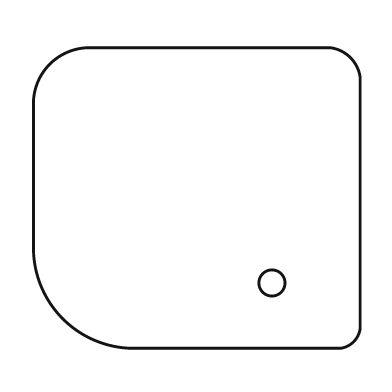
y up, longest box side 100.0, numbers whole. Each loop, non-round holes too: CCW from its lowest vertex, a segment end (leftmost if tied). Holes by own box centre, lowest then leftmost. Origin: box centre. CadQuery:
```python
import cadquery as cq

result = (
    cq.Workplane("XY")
    .moveTo(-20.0, -46.0)
    .lineTo(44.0, -46.0)
    .threePointArc((48.0, -44.0), (50.0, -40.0))
    .lineTo(50.0, 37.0)
    .threePointArc((47.0, 43.0), (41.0, 46.0))
    .lineTo(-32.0, 46.0)
    .threePointArc((-45.0, 41.0), (-50.0, 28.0))
    .lineTo(-50.0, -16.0)
    .threePointArc((-41.0, -37.0), (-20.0, -46.0))
    .close()
    .moveTo(23.0, -26.0)
    .circle(4.0)
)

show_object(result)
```